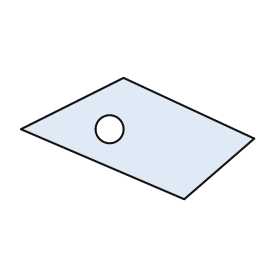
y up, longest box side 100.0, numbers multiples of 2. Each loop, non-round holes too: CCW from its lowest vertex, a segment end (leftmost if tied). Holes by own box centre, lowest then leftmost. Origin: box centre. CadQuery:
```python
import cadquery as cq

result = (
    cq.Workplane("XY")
    .moveTo(20.0, -26.0)
    .lineTo(50.0, 0.0)
    .lineTo(-6.0, 26.0)
    .lineTo(-50.0, 4.0)
    .close()
    .moveTo(-12.0, 4.0)
    .circle(6.0)
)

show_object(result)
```